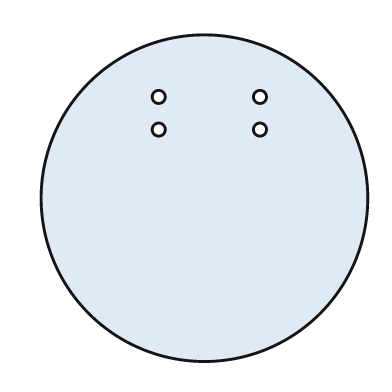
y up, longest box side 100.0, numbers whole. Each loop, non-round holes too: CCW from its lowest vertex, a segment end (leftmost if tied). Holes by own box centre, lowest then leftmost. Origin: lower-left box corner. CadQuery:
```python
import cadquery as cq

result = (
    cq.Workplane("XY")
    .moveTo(50.0, 50.0)
    .circle(50.0)
    .moveTo(36.0, 71.0)
    .circle(2.0)
    .moveTo(67.0, 71.0)
    .circle(2.0)
    .moveTo(36.0, 81.0)
    .circle(2.0)
    .moveTo(67.0, 81.0)
    .circle(2.0)
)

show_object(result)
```